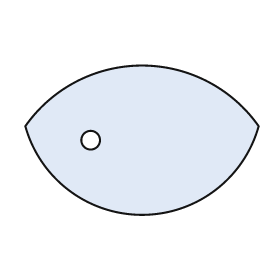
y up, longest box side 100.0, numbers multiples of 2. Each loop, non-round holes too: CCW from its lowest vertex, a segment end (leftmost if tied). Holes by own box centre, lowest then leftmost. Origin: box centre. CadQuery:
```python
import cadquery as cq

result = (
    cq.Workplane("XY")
    .moveTo(-50.0, 6.0)
    .threePointArc((0.0, -32.0), (50.0, 6.0))
    .threePointArc((0.0, 32.0), (-50.0, 6.0))
    .close()
    .moveTo(-22.0, 0.0)
    .circle(4.0)
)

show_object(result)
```